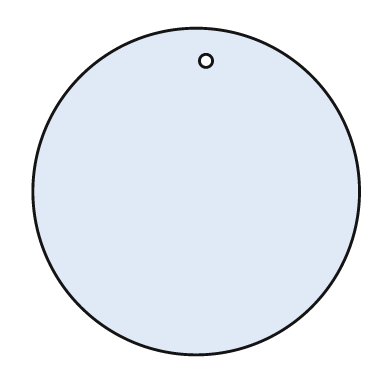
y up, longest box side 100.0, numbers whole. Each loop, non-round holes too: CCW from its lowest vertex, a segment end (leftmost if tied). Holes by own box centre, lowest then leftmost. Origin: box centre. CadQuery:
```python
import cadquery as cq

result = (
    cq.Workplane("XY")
    .moveTo(0.0, 0.0)
    .circle(50.0)
    .moveTo(3.0, 40.0)
    .circle(2.0)
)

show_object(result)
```